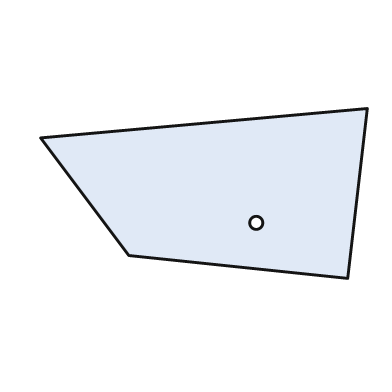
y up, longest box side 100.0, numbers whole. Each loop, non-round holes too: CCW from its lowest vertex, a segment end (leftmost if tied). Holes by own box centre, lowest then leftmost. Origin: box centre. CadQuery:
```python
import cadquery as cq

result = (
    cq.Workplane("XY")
    .moveTo(44.0, -26.0)
    .lineTo(50.0, 26.0)
    .lineTo(-50.0, 17.0)
    .lineTo(-23.0, -19.0)
    .close()
    .moveTo(16.0, -9.0)
    .circle(2.0)
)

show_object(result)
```